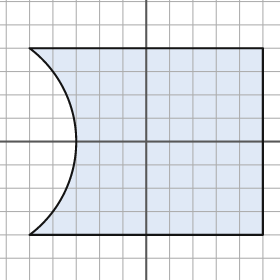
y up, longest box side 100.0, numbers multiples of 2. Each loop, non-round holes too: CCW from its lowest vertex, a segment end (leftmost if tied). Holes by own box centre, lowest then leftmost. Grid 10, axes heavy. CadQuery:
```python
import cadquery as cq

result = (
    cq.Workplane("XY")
    .moveTo(-50.0, -40.0)
    .lineTo(50.0, -40.0)
    .lineTo(50.0, 40.0)
    .lineTo(-50.0, 40.0)
    .threePointArc((-30.0, 0.0), (-50.0, -40.0))
    .close()
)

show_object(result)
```